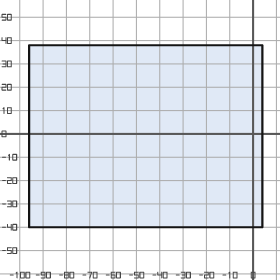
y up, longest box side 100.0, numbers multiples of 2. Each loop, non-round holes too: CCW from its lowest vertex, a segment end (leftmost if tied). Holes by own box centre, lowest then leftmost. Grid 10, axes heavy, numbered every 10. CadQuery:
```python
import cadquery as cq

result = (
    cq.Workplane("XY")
    .moveTo(-96.0, -40.0)
    .lineTo(4.0, -40.0)
    .lineTo(4.0, 38.0)
    .lineTo(-96.0, 38.0)
    .close()
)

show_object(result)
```